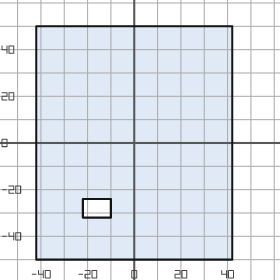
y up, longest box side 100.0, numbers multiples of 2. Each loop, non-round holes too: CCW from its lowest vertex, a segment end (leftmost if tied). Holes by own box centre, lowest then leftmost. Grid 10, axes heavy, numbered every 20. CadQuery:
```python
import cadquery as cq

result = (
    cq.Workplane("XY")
    .moveTo(-42.0, -50.0)
    .lineTo(42.0, -50.0)
    .lineTo(42.0, 50.0)
    .lineTo(-42.0, 50.0)
    .close()
    .moveTo(-22.0, -32.0)
    .lineTo(-10.0, -32.0)
    .lineTo(-10.0, -24.0)
    .lineTo(-22.0, -24.0)
    .close()
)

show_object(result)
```